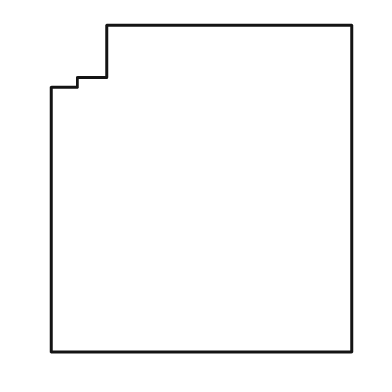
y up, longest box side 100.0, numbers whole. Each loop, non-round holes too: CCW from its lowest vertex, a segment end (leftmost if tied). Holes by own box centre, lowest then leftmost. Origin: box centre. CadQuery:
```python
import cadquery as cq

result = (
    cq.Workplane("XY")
    .moveTo(-46.0, -50.0)
    .lineTo(46.0, -50.0)
    .lineTo(46.0, 50.0)
    .lineTo(-29.0, 50.0)
    .lineTo(-29.0, 34.0)
    .lineTo(-38.0, 34.0)
    .lineTo(-38.0, 31.0)
    .lineTo(-46.0, 31.0)
    .close()
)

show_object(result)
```